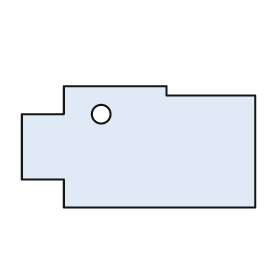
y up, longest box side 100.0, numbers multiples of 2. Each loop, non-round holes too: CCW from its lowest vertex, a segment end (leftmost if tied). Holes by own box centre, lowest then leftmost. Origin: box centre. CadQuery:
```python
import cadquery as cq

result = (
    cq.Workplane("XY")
    .moveTo(-32.0, -26.0)
    .lineTo(50.0, -26.0)
    .lineTo(50.0, 22.0)
    .lineTo(12.0, 22.0)
    .lineTo(12.0, 26.0)
    .lineTo(-32.0, 26.0)
    .lineTo(-32.0, 14.0)
    .lineTo(-50.0, 14.0)
    .lineTo(-50.0, -14.0)
    .lineTo(-32.0, -14.0)
    .close()
    .moveTo(-16.0, 14.0)
    .circle(4.0)
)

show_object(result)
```